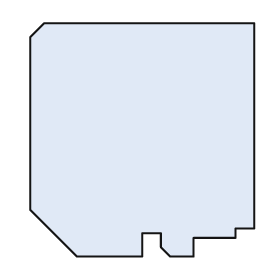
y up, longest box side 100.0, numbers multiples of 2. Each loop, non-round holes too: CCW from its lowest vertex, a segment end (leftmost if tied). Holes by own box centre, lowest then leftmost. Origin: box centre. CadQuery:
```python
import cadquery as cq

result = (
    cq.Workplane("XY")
    .moveTo(-28.0, -50.0)
    .lineTo(0.0, -50.0)
    .lineTo(0.0, -40.0)
    .lineTo(8.0, -40.0)
    .lineTo(8.0, -46.0)
    .lineTo(12.0, -50.0)
    .lineTo(22.0, -50.0)
    .lineTo(22.0, -42.0)
    .lineTo(40.0, -42.0)
    .lineTo(40.0, -38.0)
    .lineTo(48.0, -38.0)
    .lineTo(48.0, 50.0)
    .lineTo(-42.0, 50.0)
    .lineTo(-48.0, 44.0)
    .lineTo(-48.0, -30.0)
    .close()
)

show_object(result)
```